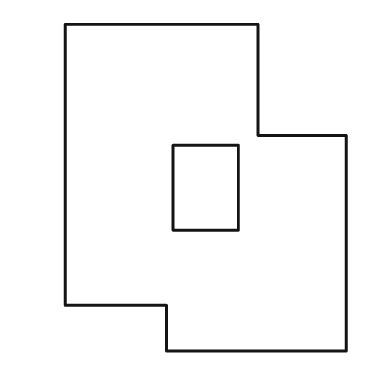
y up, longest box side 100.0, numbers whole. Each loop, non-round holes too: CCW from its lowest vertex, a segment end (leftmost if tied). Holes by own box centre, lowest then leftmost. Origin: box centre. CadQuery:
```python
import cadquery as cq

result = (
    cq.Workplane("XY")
    .moveTo(-12.0, -50.0)
    .lineTo(43.0, -50.0)
    .lineTo(43.0, 16.0)
    .lineTo(16.0, 16.0)
    .lineTo(16.0, 50.0)
    .lineTo(-43.0, 50.0)
    .lineTo(-43.0, -36.0)
    .lineTo(-12.0, -36.0)
    .close()
    .moveTo(-10.0, -13.0)
    .lineTo(10.0, -13.0)
    .lineTo(10.0, 13.0)
    .lineTo(-10.0, 13.0)
    .close()
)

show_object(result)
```